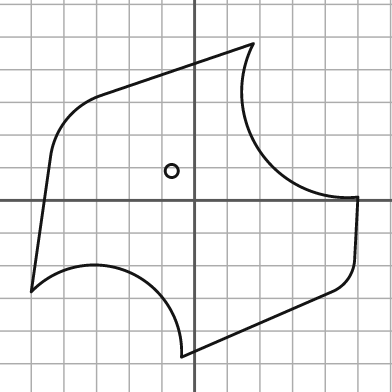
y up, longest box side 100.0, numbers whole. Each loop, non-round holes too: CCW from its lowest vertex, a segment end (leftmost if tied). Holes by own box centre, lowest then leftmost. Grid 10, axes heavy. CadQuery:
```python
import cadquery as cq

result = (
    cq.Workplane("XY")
    .moveTo(-4.0, -48.0)
    .lineTo(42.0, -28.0)
    .threePointArc((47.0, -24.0), (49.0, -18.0))
    .lineTo(50.0, 1.0)
    .threePointArc((20.0, 15.0), (18.0, 48.0))
    .lineTo(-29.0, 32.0)
    .threePointArc((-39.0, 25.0), (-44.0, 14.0))
    .lineTo(-50.0, -28.0)
    .threePointArc((-20.0, -22.0), (-4.0, -48.0))
    .close()
    .moveTo(-7.0, 9.0)
    .circle(2.0)
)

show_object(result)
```